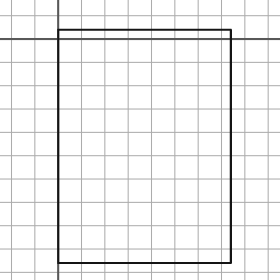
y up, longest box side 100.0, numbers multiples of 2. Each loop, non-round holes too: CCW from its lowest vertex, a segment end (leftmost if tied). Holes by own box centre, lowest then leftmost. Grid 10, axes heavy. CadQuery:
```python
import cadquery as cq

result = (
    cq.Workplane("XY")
    .moveTo(0.0, -96.0)
    .lineTo(74.0, -96.0)
    .lineTo(74.0, 4.0)
    .lineTo(0.0, 4.0)
    .close()
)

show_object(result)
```